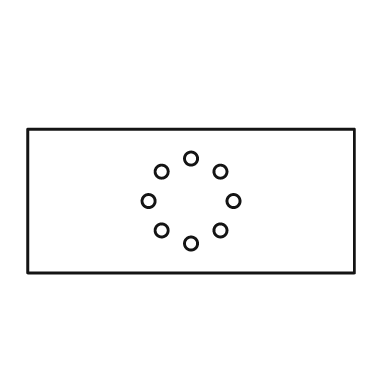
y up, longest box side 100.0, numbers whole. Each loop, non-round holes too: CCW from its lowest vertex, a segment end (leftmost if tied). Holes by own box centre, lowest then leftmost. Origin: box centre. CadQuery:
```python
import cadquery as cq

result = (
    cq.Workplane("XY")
    .moveTo(-50.0, -22.0)
    .lineTo(50.0, -22.0)
    .lineTo(50.0, 22.0)
    .lineTo(-50.0, 22.0)
    .close()
    .moveTo(0.0, -13.0)
    .circle(2.0)
    .moveTo(-9.0, -9.0)
    .circle(2.0)
    .moveTo(9.0, -9.0)
    .circle(2.0)
    .moveTo(-13.0, 0.0)
    .circle(2.0)
    .moveTo(13.0, 0.0)
    .circle(2.0)
    .moveTo(-9.0, 9.0)
    .circle(2.0)
    .moveTo(9.0, 9.0)
    .circle(2.0)
    .moveTo(0.0, 13.0)
    .circle(2.0)
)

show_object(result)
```